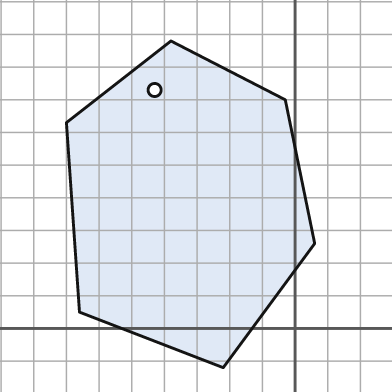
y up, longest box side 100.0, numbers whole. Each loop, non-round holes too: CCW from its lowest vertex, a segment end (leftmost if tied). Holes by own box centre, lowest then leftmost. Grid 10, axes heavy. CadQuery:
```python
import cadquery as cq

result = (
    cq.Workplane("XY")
    .moveTo(-22.0, -12.0)
    .lineTo(6.0, 26.0)
    .lineTo(-3.0, 70.0)
    .lineTo(-38.0, 88.0)
    .lineTo(-70.0, 63.0)
    .lineTo(-66.0, 5.0)
    .close()
    .moveTo(-43.0, 73.0)
    .circle(2.0)
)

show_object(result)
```